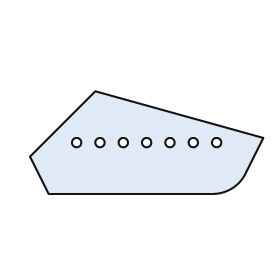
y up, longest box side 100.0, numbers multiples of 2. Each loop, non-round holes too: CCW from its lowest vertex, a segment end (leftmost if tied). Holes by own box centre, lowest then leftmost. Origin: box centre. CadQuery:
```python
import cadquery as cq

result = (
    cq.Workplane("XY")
    .moveTo(-42.0, -22.0)
    .lineTo(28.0, -22.0)
    .threePointArc((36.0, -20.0), (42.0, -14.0))
    .lineTo(50.0, 2.0)
    .lineTo(-22.0, 22.0)
    .lineTo(-50.0, -6.0)
    .close()
    .moveTo(-30.0, 0.0)
    .circle(2.0)
    .moveTo(-20.0, 0.0)
    .circle(2.0)
    .moveTo(-10.0, 0.0)
    .circle(2.0)
    .moveTo(0.0, 0.0)
    .circle(2.0)
    .moveTo(10.0, 0.0)
    .circle(2.0)
    .moveTo(20.0, 0.0)
    .circle(2.0)
    .moveTo(30.0, 0.0)
    .circle(2.0)
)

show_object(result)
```